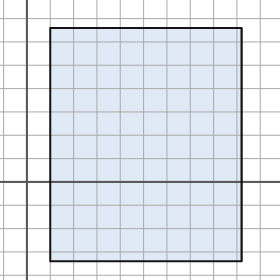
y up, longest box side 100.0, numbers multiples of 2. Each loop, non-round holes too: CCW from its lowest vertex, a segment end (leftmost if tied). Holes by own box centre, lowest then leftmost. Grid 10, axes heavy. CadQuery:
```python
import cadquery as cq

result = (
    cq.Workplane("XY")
    .moveTo(10.0, -34.0)
    .lineTo(92.0, -34.0)
    .lineTo(92.0, 66.0)
    .lineTo(10.0, 66.0)
    .close()
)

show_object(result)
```